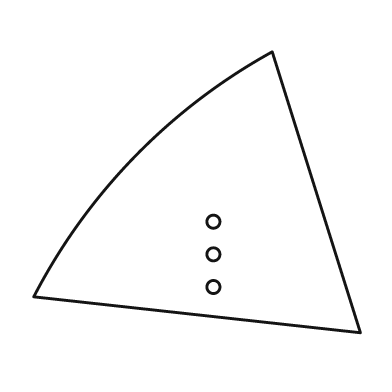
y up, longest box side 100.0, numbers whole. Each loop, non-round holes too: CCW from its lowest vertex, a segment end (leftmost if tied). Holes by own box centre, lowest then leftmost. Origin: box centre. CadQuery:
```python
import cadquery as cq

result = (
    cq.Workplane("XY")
    .moveTo(50.0, -43.0)
    .lineTo(23.0, 43.0)
    .threePointArc((-19.0, 11.0), (-50.0, -32.0))
    .close()
    .moveTo(5.0, -29.0)
    .circle(2.0)
    .moveTo(5.0, -19.0)
    .circle(2.0)
    .moveTo(5.0, -9.0)
    .circle(2.0)
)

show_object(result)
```